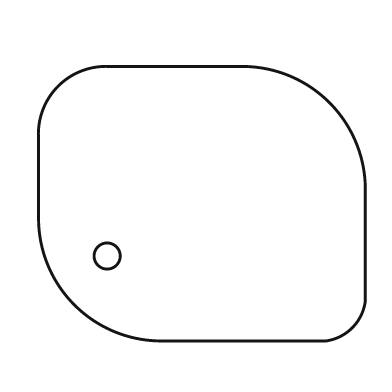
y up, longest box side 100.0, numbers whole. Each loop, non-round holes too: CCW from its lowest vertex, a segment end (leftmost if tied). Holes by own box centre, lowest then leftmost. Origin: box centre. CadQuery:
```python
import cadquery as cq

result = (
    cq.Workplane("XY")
    .moveTo(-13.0, -42.0)
    .lineTo(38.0, -42.0)
    .threePointArc((46.0, -38.0), (50.0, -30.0))
    .lineTo(50.0, 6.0)
    .threePointArc((39.0, 31.0), (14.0, 42.0))
    .lineTo(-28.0, 42.0)
    .threePointArc((-44.0, 36.0), (-50.0, 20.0))
    .lineTo(-50.0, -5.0)
    .threePointArc((-39.0, -31.0), (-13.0, -42.0))
    .close()
    .moveTo(-29.0, -16.0)
    .circle(4.0)
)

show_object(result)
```